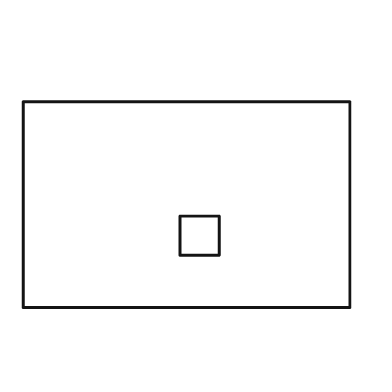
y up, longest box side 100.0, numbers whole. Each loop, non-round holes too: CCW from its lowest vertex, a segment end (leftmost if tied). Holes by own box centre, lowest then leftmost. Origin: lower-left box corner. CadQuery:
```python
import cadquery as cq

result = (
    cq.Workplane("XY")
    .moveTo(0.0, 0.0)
    .lineTo(100.0, 0.0)
    .lineTo(100.0, 63.0)
    .lineTo(0.0, 63.0)
    .close()
    .moveTo(48.0, 16.0)
    .lineTo(60.0, 16.0)
    .lineTo(60.0, 28.0)
    .lineTo(48.0, 28.0)
    .close()
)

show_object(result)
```